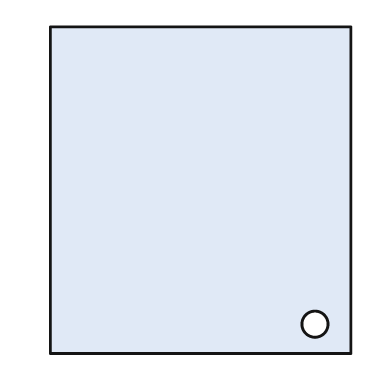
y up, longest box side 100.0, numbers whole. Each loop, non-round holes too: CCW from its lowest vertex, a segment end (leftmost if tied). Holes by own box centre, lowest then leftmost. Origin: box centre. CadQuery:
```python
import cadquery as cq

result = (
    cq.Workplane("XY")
    .moveTo(-46.0, -50.0)
    .lineTo(46.0, -50.0)
    .lineTo(46.0, 50.0)
    .lineTo(-46.0, 50.0)
    .close()
    .moveTo(35.0, -41.0)
    .circle(4.0)
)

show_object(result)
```